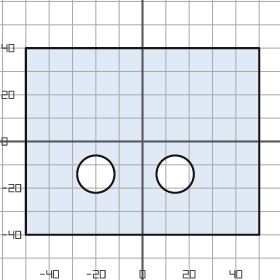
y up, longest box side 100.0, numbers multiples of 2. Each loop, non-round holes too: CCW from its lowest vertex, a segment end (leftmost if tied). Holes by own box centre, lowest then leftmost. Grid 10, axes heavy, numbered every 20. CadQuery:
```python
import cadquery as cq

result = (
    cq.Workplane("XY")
    .moveTo(-50.0, -40.0)
    .lineTo(50.0, -40.0)
    .lineTo(50.0, 40.0)
    .lineTo(-50.0, 40.0)
    .close()
    .moveTo(-20.0, -14.0)
    .circle(8.0)
    .moveTo(14.0, -14.0)
    .circle(8.0)
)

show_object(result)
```